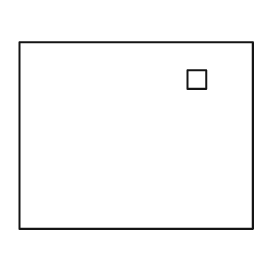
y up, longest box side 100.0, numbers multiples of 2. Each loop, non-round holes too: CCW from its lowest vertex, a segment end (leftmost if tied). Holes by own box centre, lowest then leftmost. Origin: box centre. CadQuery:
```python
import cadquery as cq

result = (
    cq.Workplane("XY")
    .moveTo(-50.0, -40.0)
    .lineTo(50.0, -40.0)
    .lineTo(50.0, 40.0)
    .lineTo(-50.0, 40.0)
    .close()
    .moveTo(22.0, 20.0)
    .lineTo(30.0, 20.0)
    .lineTo(30.0, 28.0)
    .lineTo(22.0, 28.0)
    .close()
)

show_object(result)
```